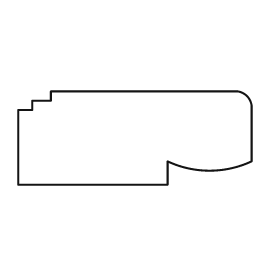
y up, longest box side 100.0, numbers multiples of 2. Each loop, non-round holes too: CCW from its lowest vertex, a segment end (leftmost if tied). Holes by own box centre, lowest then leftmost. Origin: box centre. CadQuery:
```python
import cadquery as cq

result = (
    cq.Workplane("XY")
    .moveTo(-50.0, -20.0)
    .lineTo(14.0, -20.0)
    .lineTo(14.0, -10.0)
    .threePointArc((32.0, -14.0), (50.0, -10.0))
    .lineTo(50.0, 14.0)
    .threePointArc((48.0, 18.0), (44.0, 20.0))
    .lineTo(-36.0, 20.0)
    .lineTo(-36.0, 16.0)
    .lineTo(-44.0, 16.0)
    .lineTo(-44.0, 12.0)
    .lineTo(-50.0, 12.0)
    .close()
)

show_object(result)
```